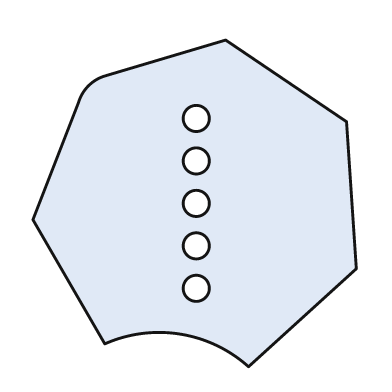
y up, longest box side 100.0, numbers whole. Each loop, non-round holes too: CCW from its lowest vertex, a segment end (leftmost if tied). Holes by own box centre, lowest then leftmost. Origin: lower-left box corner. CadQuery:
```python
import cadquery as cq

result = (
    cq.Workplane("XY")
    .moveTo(66.0, 0.0)
    .lineTo(99.0, 30.0)
    .lineTo(96.0, 75.0)
    .lineTo(59.0, 100.0)
    .lineTo(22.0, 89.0)
    .threePointArc((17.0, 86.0), (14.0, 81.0))
    .lineTo(0.0, 45.0)
    .lineTo(22.0, 7.0)
    .threePointArc((45.0, 10.0), (66.0, 0.0))
    .close()
    .moveTo(50.0, 24.0)
    .circle(4.0)
    .moveTo(50.0, 37.0)
    .circle(4.0)
    .moveTo(50.0, 50.0)
    .circle(4.0)
    .moveTo(50.0, 63.0)
    .circle(4.0)
    .moveTo(50.0, 76.0)
    .circle(4.0)
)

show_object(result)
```